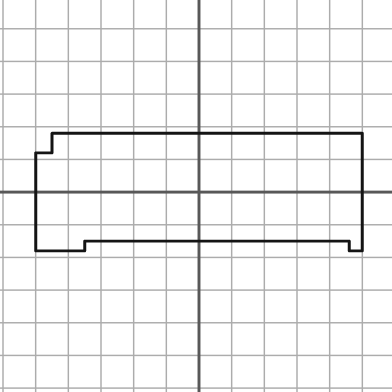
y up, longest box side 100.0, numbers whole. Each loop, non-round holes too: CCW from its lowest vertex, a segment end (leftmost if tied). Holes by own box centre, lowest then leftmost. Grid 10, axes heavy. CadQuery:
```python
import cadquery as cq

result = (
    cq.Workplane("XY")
    .moveTo(-50.0, -18.0)
    .lineTo(-35.0, -18.0)
    .lineTo(-35.0, -15.0)
    .lineTo(46.0, -15.0)
    .lineTo(46.0, -18.0)
    .lineTo(50.0, -18.0)
    .lineTo(50.0, 18.0)
    .lineTo(-45.0, 18.0)
    .lineTo(-45.0, 12.0)
    .lineTo(-50.0, 12.0)
    .close()
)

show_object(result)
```